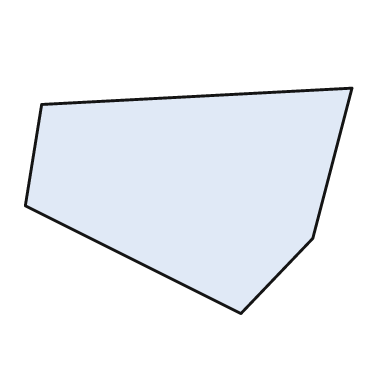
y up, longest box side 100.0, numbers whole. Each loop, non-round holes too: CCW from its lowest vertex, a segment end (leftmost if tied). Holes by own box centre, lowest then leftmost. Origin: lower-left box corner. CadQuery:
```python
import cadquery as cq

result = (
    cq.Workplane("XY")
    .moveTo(66.0, 0.0)
    .lineTo(88.0, 23.0)
    .lineTo(100.0, 69.0)
    .lineTo(5.0, 64.0)
    .lineTo(0.0, 33.0)
    .close()
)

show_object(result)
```